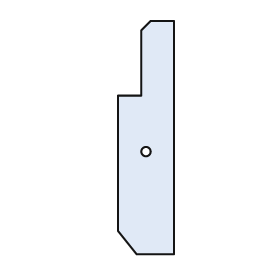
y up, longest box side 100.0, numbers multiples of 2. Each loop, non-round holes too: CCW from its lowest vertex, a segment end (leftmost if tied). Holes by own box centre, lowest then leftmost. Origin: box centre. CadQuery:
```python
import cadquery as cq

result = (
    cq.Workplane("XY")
    .moveTo(-4.0, -50.0)
    .lineTo(12.0, -50.0)
    .lineTo(12.0, 50.0)
    .lineTo(2.0, 50.0)
    .lineTo(-2.0, 46.0)
    .lineTo(-2.0, 18.0)
    .lineTo(-12.0, 18.0)
    .lineTo(-12.0, -40.0)
    .close()
    .moveTo(0.0, -6.0)
    .circle(2.0)
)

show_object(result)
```